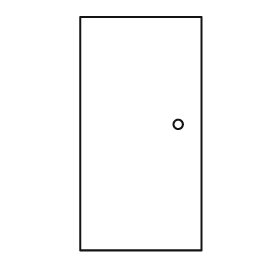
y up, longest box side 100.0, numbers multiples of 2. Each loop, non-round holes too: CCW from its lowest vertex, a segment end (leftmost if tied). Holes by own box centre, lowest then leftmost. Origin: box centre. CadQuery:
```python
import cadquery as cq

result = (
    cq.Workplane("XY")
    .moveTo(-26.0, -50.0)
    .lineTo(26.0, -50.0)
    .lineTo(26.0, 50.0)
    .lineTo(-26.0, 50.0)
    .close()
    .moveTo(16.0, 4.0)
    .circle(2.0)
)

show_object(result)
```